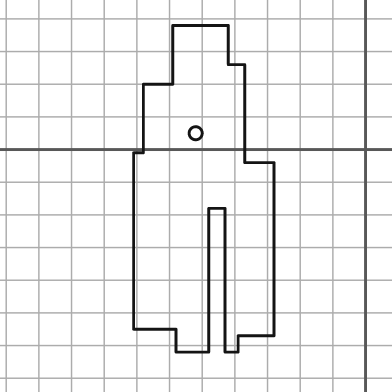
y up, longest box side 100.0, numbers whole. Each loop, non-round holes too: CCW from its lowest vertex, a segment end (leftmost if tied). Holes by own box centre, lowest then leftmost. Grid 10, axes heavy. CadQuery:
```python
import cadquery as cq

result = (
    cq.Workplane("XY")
    .moveTo(-58.0, -62.0)
    .lineTo(-48.0, -62.0)
    .lineTo(-48.0, -18.0)
    .lineTo(-43.0, -18.0)
    .lineTo(-43.0, -62.0)
    .lineTo(-39.0, -62.0)
    .lineTo(-39.0, -57.0)
    .lineTo(-28.0, -57.0)
    .lineTo(-28.0, -4.0)
    .lineTo(-37.0, -4.0)
    .lineTo(-37.0, 26.0)
    .lineTo(-42.0, 26.0)
    .lineTo(-42.0, 38.0)
    .lineTo(-59.0, 38.0)
    .lineTo(-59.0, 20.0)
    .lineTo(-68.0, 20.0)
    .lineTo(-68.0, -1.0)
    .lineTo(-71.0, -1.0)
    .lineTo(-71.0, -55.0)
    .lineTo(-58.0, -55.0)
    .close()
    .moveTo(-52.0, 5.0)
    .circle(2.0)
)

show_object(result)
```